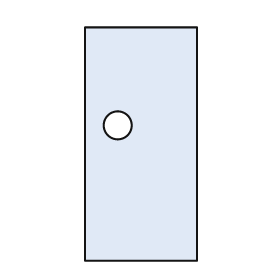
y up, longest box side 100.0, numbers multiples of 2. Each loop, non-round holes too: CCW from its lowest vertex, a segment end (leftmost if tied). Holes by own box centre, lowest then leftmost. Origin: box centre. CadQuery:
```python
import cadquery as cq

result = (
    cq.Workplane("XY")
    .moveTo(-24.0, -50.0)
    .lineTo(24.0, -50.0)
    .lineTo(24.0, 50.0)
    .lineTo(-24.0, 50.0)
    .close()
    .moveTo(-10.0, 8.0)
    .circle(6.0)
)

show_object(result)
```